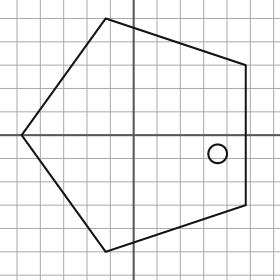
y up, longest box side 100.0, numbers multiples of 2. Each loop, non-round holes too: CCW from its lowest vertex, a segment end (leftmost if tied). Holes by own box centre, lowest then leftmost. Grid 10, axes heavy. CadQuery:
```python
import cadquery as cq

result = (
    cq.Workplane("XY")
    .moveTo(-12.0, -50.0)
    .lineTo(48.0, -30.0)
    .lineTo(48.0, 30.0)
    .lineTo(-12.0, 50.0)
    .lineTo(-48.0, 0.0)
    .close()
    .moveTo(36.0, -8.0)
    .circle(4.0)
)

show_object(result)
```